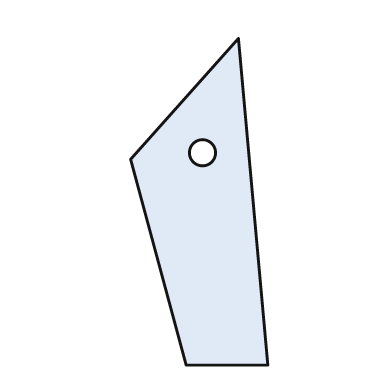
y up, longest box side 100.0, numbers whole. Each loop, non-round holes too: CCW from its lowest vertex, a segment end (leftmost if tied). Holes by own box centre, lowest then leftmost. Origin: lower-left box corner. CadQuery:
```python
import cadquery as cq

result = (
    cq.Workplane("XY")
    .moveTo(17.0, 0.0)
    .lineTo(42.0, 0.0)
    .lineTo(33.0, 100.0)
    .lineTo(0.0, 63.0)
    .close()
    .moveTo(22.0, 65.0)
    .circle(4.0)
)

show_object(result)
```